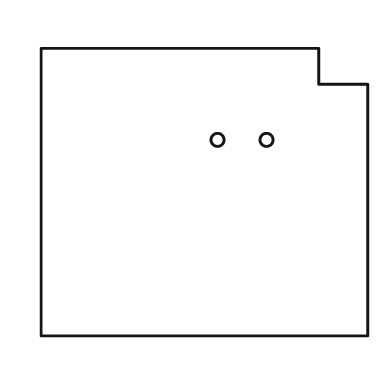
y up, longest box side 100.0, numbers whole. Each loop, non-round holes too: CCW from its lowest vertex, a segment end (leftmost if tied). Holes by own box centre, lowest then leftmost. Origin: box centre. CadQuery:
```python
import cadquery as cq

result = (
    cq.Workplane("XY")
    .moveTo(-50.0, -44.0)
    .lineTo(50.0, -44.0)
    .lineTo(50.0, 33.0)
    .lineTo(35.0, 33.0)
    .lineTo(35.0, 44.0)
    .lineTo(-50.0, 44.0)
    .close()
    .moveTo(4.0, 16.0)
    .circle(2.0)
    .moveTo(19.0, 16.0)
    .circle(2.0)
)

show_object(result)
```